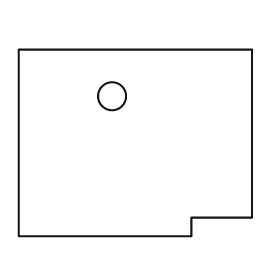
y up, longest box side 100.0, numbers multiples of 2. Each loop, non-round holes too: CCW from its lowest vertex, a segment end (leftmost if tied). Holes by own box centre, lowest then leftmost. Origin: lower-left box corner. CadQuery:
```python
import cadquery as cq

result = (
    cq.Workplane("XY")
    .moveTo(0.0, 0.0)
    .lineTo(74.0, 0.0)
    .lineTo(74.0, 8.0)
    .lineTo(100.0, 8.0)
    .lineTo(100.0, 80.0)
    .lineTo(0.0, 80.0)
    .close()
    .moveTo(40.0, 60.0)
    .circle(6.0)
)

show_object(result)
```